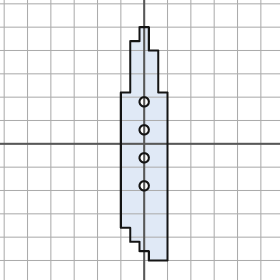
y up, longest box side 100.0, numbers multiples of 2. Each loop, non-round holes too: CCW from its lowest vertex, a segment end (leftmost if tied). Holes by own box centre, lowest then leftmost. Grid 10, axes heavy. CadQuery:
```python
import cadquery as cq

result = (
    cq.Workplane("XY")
    .moveTo(2.0, -50.0)
    .lineTo(10.0, -50.0)
    .lineTo(10.0, 22.0)
    .lineTo(6.0, 22.0)
    .lineTo(6.0, 40.0)
    .lineTo(2.0, 40.0)
    .lineTo(2.0, 50.0)
    .lineTo(-2.0, 50.0)
    .lineTo(-2.0, 44.0)
    .lineTo(-6.0, 44.0)
    .lineTo(-6.0, 22.0)
    .lineTo(-10.0, 22.0)
    .lineTo(-10.0, -36.0)
    .lineTo(-6.0, -36.0)
    .lineTo(-6.0, -42.0)
    .lineTo(-2.0, -42.0)
    .lineTo(-2.0, -46.0)
    .lineTo(2.0, -46.0)
    .close()
    .moveTo(0.0, -18.0)
    .circle(2.0)
    .moveTo(0.0, -6.0)
    .circle(2.0)
    .moveTo(0.0, 6.0)
    .circle(2.0)
    .moveTo(0.0, 18.0)
    .circle(2.0)
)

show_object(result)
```